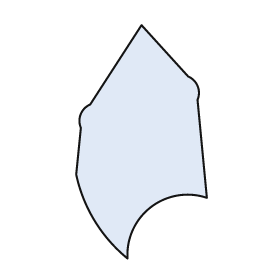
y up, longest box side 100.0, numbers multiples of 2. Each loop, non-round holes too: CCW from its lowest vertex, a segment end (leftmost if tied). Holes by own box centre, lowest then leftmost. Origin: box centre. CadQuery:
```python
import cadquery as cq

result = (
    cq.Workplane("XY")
    .moveTo(-6.0, -50.0)
    .threePointArc((4.0, -28.0), (28.0, -24.0))
    .lineTo(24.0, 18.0)
    .threePointArc((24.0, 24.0), (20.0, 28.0))
    .lineTo(0.0, 50.0)
    .lineTo(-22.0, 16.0)
    .threePointArc((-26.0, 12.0), (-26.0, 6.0))
    .lineTo(-28.0, -14.0)
    .threePointArc((-20.0, -34.0), (-6.0, -50.0))
    .close()
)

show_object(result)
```